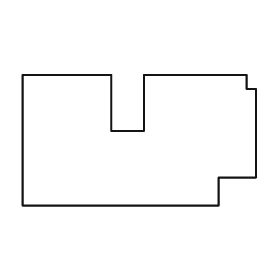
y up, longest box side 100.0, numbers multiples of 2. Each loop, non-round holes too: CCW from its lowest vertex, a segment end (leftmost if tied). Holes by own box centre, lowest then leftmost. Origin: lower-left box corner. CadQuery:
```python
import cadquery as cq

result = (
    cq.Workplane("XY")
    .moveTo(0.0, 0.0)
    .lineTo(84.0, 0.0)
    .lineTo(84.0, 12.0)
    .lineTo(100.0, 12.0)
    .lineTo(100.0, 50.0)
    .lineTo(96.0, 50.0)
    .lineTo(96.0, 56.0)
    .lineTo(52.0, 56.0)
    .lineTo(52.0, 32.0)
    .lineTo(38.0, 32.0)
    .lineTo(38.0, 56.0)
    .lineTo(0.0, 56.0)
    .close()
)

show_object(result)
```